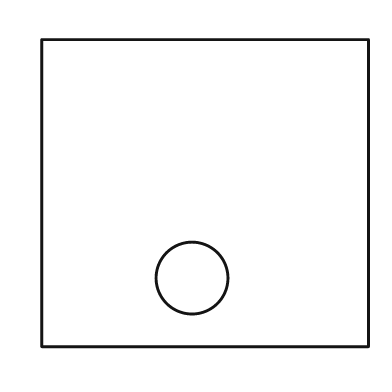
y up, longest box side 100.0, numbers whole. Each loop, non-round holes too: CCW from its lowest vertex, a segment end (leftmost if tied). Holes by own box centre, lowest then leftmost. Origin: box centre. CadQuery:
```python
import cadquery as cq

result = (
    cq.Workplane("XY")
    .moveTo(-50.0, -47.0)
    .lineTo(50.0, -47.0)
    .lineTo(50.0, 47.0)
    .lineTo(-50.0, 47.0)
    .close()
    .moveTo(-4.0, -26.0)
    .circle(11.0)
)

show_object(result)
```